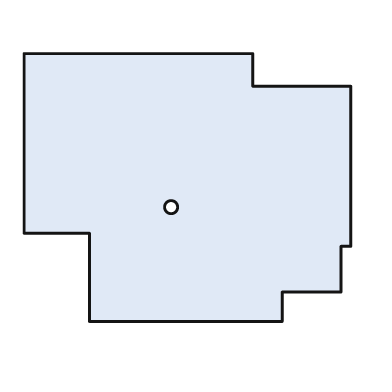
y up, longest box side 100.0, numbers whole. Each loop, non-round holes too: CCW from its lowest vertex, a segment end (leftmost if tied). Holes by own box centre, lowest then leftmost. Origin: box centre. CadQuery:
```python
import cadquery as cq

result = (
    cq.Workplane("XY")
    .moveTo(-30.0, -41.0)
    .lineTo(29.0, -41.0)
    .lineTo(29.0, -32.0)
    .lineTo(47.0, -32.0)
    .lineTo(47.0, -18.0)
    .lineTo(50.0, -18.0)
    .lineTo(50.0, 31.0)
    .lineTo(20.0, 31.0)
    .lineTo(20.0, 41.0)
    .lineTo(-50.0, 41.0)
    .lineTo(-50.0, -14.0)
    .lineTo(-30.0, -14.0)
    .close()
    .moveTo(-5.0, -6.0)
    .circle(2.0)
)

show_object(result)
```